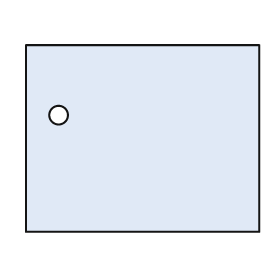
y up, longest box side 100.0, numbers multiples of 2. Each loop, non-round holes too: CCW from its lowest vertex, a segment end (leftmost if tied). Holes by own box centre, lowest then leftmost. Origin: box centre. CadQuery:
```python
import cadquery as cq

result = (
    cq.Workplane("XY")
    .moveTo(-50.0, -40.0)
    .lineTo(50.0, -40.0)
    .lineTo(50.0, 40.0)
    .lineTo(-50.0, 40.0)
    .close()
    .moveTo(-36.0, 10.0)
    .circle(4.0)
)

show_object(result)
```